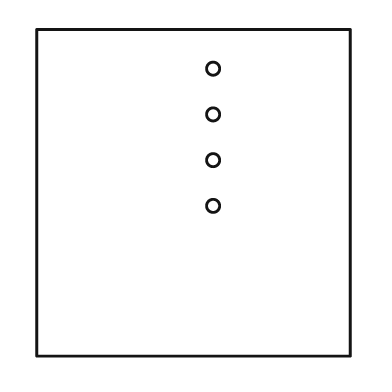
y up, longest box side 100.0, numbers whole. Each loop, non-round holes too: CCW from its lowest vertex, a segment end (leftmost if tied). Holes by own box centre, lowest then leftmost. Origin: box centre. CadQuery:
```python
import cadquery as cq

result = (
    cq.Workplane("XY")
    .moveTo(-48.0, -50.0)
    .lineTo(48.0, -50.0)
    .lineTo(48.0, 50.0)
    .lineTo(-48.0, 50.0)
    .close()
    .moveTo(6.0, -4.0)
    .circle(2.0)
    .moveTo(6.0, 10.0)
    .circle(2.0)
    .moveTo(6.0, 24.0)
    .circle(2.0)
    .moveTo(6.0, 38.0)
    .circle(2.0)
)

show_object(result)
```